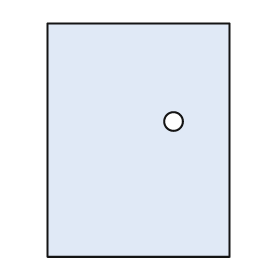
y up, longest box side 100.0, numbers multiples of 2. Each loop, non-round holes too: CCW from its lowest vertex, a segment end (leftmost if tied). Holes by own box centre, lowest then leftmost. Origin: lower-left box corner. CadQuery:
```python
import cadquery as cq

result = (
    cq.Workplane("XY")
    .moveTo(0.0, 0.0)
    .lineTo(78.0, 0.0)
    .lineTo(78.0, 100.0)
    .lineTo(0.0, 100.0)
    .close()
    .moveTo(54.0, 58.0)
    .circle(4.0)
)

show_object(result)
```